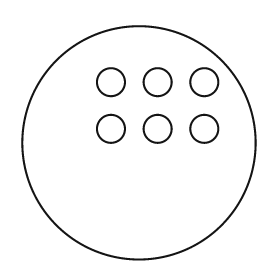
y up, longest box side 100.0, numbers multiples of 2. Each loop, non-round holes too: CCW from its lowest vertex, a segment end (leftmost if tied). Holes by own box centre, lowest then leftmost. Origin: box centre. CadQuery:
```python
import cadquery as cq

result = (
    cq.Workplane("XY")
    .moveTo(0.0, 0.0)
    .circle(50.0)
    .moveTo(-12.0, 6.0)
    .circle(6.0)
    .moveTo(8.0, 6.0)
    .circle(6.0)
    .moveTo(28.0, 6.0)
    .circle(6.0)
    .moveTo(-12.0, 26.0)
    .circle(6.0)
    .moveTo(8.0, 26.0)
    .circle(6.0)
    .moveTo(28.0, 26.0)
    .circle(6.0)
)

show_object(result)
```